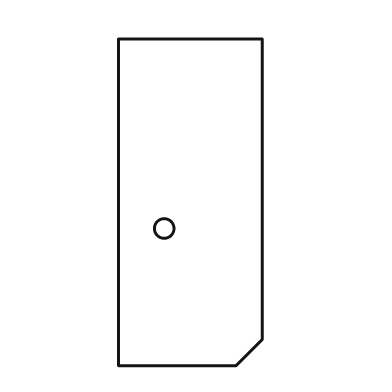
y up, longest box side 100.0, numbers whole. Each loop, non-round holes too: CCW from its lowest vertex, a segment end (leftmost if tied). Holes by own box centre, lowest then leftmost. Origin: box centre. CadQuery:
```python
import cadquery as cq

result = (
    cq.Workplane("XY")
    .moveTo(-22.0, -50.0)
    .lineTo(14.0, -50.0)
    .lineTo(22.0, -42.0)
    .lineTo(22.0, 50.0)
    .lineTo(-22.0, 50.0)
    .close()
    .moveTo(-8.0, -8.0)
    .circle(3.0)
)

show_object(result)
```